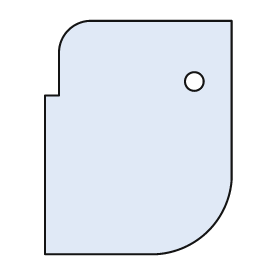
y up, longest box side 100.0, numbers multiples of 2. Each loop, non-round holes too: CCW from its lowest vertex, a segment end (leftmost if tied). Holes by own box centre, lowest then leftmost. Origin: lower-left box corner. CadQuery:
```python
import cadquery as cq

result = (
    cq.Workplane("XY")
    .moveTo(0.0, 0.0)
    .lineTo(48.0, 0.0)
    .threePointArc((70.0, 10.0), (80.0, 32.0))
    .lineTo(80.0, 100.0)
    .lineTo(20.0, 100.0)
    .threePointArc((10.0, 96.0), (6.0, 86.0))
    .lineTo(6.0, 68.0)
    .lineTo(0.0, 68.0)
    .close()
    .moveTo(64.0, 74.0)
    .circle(4.0)
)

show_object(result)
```